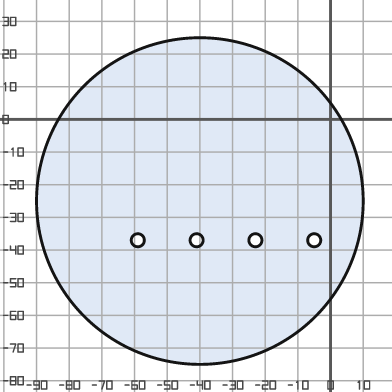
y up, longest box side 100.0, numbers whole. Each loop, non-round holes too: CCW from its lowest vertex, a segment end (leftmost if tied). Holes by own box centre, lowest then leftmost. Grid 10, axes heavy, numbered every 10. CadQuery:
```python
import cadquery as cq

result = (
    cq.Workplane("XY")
    .moveTo(-40.0, -25.0)
    .circle(50.0)
    .moveTo(-59.0, -37.0)
    .circle(2.0)
    .moveTo(-41.0, -37.0)
    .circle(2.0)
    .moveTo(-23.0, -37.0)
    .circle(2.0)
    .moveTo(-5.0, -37.0)
    .circle(2.0)
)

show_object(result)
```